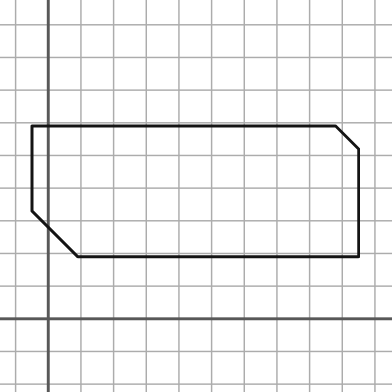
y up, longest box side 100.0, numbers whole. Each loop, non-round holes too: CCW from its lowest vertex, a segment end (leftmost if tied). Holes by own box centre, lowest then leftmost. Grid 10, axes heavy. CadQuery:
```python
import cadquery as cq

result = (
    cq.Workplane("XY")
    .moveTo(9.0, 19.0)
    .lineTo(95.0, 19.0)
    .lineTo(95.0, 52.0)
    .lineTo(88.0, 59.0)
    .lineTo(-5.0, 59.0)
    .lineTo(-5.0, 33.0)
    .close()
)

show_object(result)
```